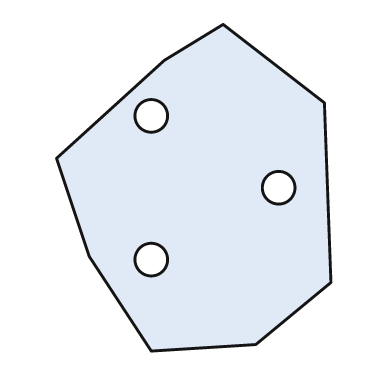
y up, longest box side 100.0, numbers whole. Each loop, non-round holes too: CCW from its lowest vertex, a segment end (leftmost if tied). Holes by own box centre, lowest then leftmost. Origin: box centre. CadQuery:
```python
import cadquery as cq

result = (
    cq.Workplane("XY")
    .moveTo(-13.0, -50.0)
    .lineTo(19.0, -48.0)
    .lineTo(42.0, -29.0)
    .lineTo(40.0, 26.0)
    .lineTo(9.0, 50.0)
    .lineTo(-9.0, 39.0)
    .lineTo(-42.0, 9.0)
    .lineTo(-32.0, -21.0)
    .close()
    .moveTo(-13.0, -22.0)
    .circle(5.0)
    .moveTo(26.0, 0.0)
    .circle(5.0)
    .moveTo(-13.0, 22.0)
    .circle(5.0)
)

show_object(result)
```